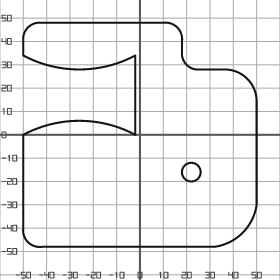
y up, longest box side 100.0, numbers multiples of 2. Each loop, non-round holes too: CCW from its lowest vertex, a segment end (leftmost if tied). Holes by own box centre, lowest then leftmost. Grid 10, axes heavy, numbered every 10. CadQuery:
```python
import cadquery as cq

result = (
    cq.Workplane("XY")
    .moveTo(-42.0, -48.0)
    .lineTo(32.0, -48.0)
    .threePointArc((44.0, -42.0), (50.0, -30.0))
    .lineTo(50.0, 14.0)
    .threePointArc((46.0, 24.0), (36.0, 28.0))
    .lineTo(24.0, 28.0)
    .threePointArc((20.0, 30.0), (18.0, 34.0))
    .lineTo(18.0, 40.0)
    .threePointArc((16.0, 46.0), (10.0, 48.0))
    .lineTo(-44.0, 48.0)
    .threePointArc((-48.0, 46.0), (-50.0, 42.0))
    .lineTo(-50.0, 34.0)
    .threePointArc((-26.0, 28.0), (-2.0, 34.0))
    .lineTo(-2.0, 0.0)
    .threePointArc((-26.0, 6.0), (-50.0, 0.0))
    .lineTo(-50.0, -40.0)
    .threePointArc((-48.0, -46.0), (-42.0, -48.0))
    .close()
    .moveTo(22.0, -16.0)
    .circle(4.0)
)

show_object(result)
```